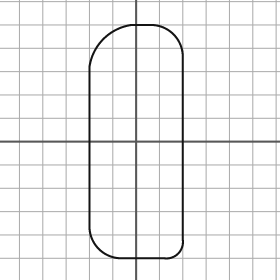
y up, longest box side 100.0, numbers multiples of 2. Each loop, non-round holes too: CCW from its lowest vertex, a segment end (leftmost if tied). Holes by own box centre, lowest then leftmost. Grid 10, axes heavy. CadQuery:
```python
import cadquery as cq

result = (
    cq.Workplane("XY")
    .moveTo(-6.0, -50.0)
    .lineTo(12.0, -50.0)
    .threePointArc((18.0, -48.0), (20.0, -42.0))
    .lineTo(20.0, 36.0)
    .threePointArc((16.0, 46.0), (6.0, 50.0))
    .lineTo(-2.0, 50.0)
    .threePointArc((-14.0, 44.0), (-20.0, 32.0))
    .lineTo(-20.0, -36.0)
    .threePointArc((-16.0, -46.0), (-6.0, -50.0))
    .close()
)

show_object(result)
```